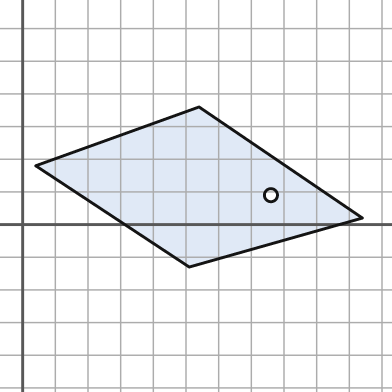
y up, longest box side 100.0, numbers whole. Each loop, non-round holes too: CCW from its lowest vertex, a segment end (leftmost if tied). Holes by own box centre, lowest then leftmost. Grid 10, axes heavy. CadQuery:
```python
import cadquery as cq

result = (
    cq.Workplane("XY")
    .moveTo(51.0, -13.0)
    .lineTo(104.0, 2.0)
    .lineTo(54.0, 36.0)
    .lineTo(4.0, 18.0)
    .close()
    .moveTo(76.0, 9.0)
    .circle(2.0)
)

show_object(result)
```